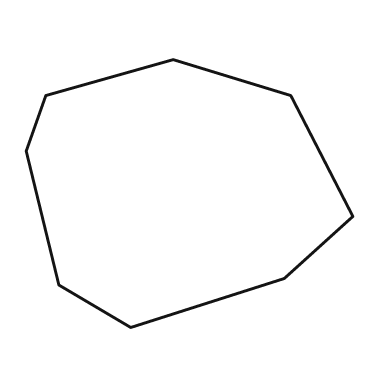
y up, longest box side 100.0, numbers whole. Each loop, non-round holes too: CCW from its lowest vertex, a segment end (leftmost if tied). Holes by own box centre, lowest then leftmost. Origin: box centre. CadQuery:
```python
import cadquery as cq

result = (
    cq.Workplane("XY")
    .moveTo(-18.0, -41.0)
    .lineTo(29.0, -26.0)
    .lineTo(50.0, -7.0)
    .lineTo(31.0, 30.0)
    .lineTo(-5.0, 41.0)
    .lineTo(-44.0, 30.0)
    .lineTo(-50.0, 13.0)
    .lineTo(-40.0, -28.0)
    .close()
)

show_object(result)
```